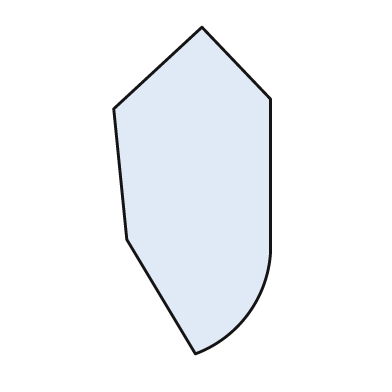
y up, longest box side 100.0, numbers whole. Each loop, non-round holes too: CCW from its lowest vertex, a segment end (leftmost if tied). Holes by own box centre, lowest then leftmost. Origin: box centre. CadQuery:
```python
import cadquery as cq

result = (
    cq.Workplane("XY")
    .moveTo(1.0, -50.0)
    .threePointArc((17.0, -38.0), (24.0, -19.0))
    .lineTo(24.0, 28.0)
    .lineTo(3.0, 50.0)
    .lineTo(-24.0, 25.0)
    .lineTo(-20.0, -15.0)
    .close()
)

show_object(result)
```